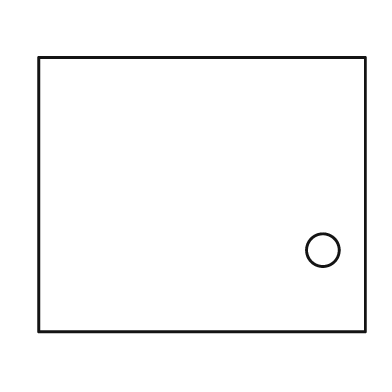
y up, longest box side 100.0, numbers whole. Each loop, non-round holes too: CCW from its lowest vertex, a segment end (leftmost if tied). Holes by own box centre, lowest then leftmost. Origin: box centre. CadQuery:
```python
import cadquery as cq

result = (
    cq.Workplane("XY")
    .moveTo(-50.0, -42.0)
    .lineTo(50.0, -42.0)
    .lineTo(50.0, 42.0)
    .lineTo(-50.0, 42.0)
    .close()
    .moveTo(37.0, -17.0)
    .circle(5.0)
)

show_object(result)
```